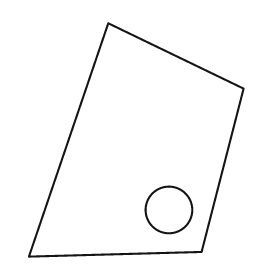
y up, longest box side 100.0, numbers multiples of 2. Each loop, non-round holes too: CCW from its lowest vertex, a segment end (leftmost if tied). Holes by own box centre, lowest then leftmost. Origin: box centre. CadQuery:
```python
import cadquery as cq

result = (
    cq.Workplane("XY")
    .moveTo(-46.0, -50.0)
    .lineTo(28.0, -48.0)
    .lineTo(46.0, 22.0)
    .lineTo(-12.0, 50.0)
    .close()
    .moveTo(14.0, -30.0)
    .circle(10.0)
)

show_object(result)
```